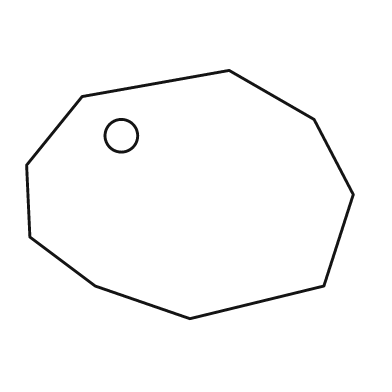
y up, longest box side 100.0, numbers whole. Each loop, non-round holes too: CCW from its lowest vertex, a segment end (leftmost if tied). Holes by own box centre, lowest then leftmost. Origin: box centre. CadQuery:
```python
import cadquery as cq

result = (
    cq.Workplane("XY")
    .moveTo(0.0, -38.0)
    .lineTo(41.0, -28.0)
    .lineTo(50.0, 0.0)
    .lineTo(38.0, 23.0)
    .lineTo(12.0, 38.0)
    .lineTo(-33.0, 30.0)
    .lineTo(-50.0, 9.0)
    .lineTo(-49.0, -13.0)
    .lineTo(-29.0, -28.0)
    .close()
    .moveTo(-21.0, 18.0)
    .circle(5.0)
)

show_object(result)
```